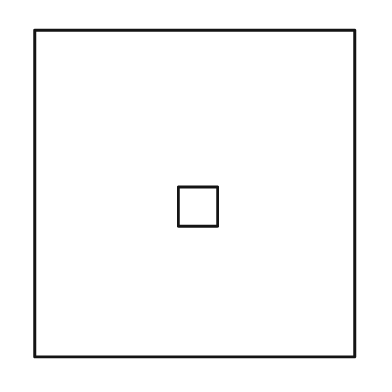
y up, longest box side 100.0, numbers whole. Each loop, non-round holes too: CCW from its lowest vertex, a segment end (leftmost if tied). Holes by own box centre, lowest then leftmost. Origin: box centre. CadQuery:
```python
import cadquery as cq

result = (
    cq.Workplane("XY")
    .moveTo(-49.0, -50.0)
    .lineTo(49.0, -50.0)
    .lineTo(49.0, 50.0)
    .lineTo(-49.0, 50.0)
    .close()
    .moveTo(-5.0, -10.0)
    .lineTo(7.0, -10.0)
    .lineTo(7.0, 2.0)
    .lineTo(-5.0, 2.0)
    .close()
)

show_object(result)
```